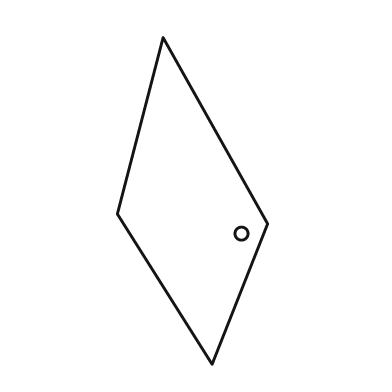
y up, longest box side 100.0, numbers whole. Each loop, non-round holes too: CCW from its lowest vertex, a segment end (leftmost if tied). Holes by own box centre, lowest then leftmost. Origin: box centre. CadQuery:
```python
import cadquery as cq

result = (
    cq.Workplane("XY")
    .moveTo(6.0, -50.0)
    .lineTo(23.0, -7.0)
    .lineTo(-9.0, 50.0)
    .lineTo(-23.0, -4.0)
    .close()
    .moveTo(15.0, -10.0)
    .circle(2.0)
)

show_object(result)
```